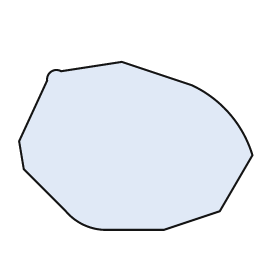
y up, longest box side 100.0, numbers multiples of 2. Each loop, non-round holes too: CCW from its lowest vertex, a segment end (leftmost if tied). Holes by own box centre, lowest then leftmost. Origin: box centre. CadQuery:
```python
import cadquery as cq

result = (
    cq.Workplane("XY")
    .moveTo(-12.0, -36.0)
    .lineTo(12.0, -36.0)
    .lineTo(36.0, -28.0)
    .lineTo(50.0, -4.0)
    .threePointArc((40.0, 14.0), (24.0, 26.0))
    .lineTo(-6.0, 36.0)
    .lineTo(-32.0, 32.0)
    .threePointArc((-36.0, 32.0), (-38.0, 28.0))
    .lineTo(-50.0, 2.0)
    .lineTo(-48.0, -10.0)
    .lineTo(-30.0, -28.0)
    .threePointArc((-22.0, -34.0), (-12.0, -36.0))
    .close()
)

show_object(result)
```